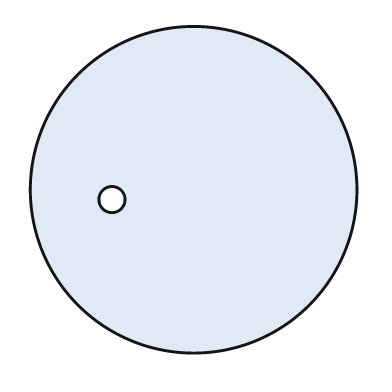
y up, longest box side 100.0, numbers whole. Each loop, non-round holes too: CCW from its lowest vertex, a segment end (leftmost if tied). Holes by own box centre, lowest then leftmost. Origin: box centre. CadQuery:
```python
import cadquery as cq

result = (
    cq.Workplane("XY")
    .moveTo(0.0, 0.0)
    .circle(50.0)
    .moveTo(-25.0, -3.0)
    .circle(4.0)
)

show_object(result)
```